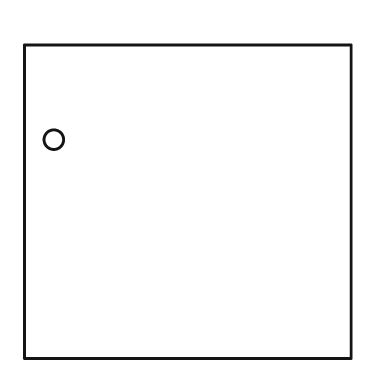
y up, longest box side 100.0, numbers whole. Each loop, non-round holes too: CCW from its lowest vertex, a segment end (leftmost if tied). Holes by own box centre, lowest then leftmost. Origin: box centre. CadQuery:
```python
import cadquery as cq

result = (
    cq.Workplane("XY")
    .moveTo(-50.0, -48.0)
    .lineTo(50.0, -48.0)
    .lineTo(50.0, 48.0)
    .lineTo(-50.0, 48.0)
    .close()
    .moveTo(-41.0, 19.0)
    .circle(3.0)
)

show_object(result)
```